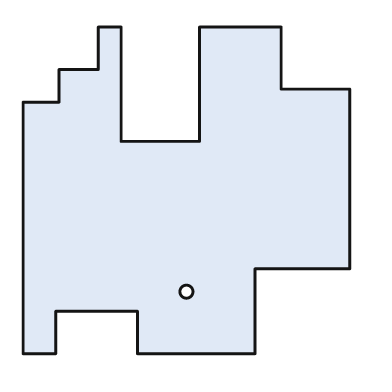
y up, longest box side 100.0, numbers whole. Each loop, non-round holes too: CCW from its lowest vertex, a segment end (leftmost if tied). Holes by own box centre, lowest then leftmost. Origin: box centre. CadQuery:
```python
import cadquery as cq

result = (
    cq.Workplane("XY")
    .moveTo(-50.0, -50.0)
    .lineTo(-40.0, -50.0)
    .lineTo(-40.0, -37.0)
    .lineTo(-15.0, -37.0)
    .lineTo(-15.0, -50.0)
    .lineTo(21.0, -50.0)
    .lineTo(21.0, -24.0)
    .lineTo(50.0, -24.0)
    .lineTo(50.0, 31.0)
    .lineTo(29.0, 31.0)
    .lineTo(29.0, 50.0)
    .lineTo(4.0, 50.0)
    .lineTo(4.0, 15.0)
    .lineTo(-20.0, 15.0)
    .lineTo(-20.0, 50.0)
    .lineTo(-27.0, 50.0)
    .lineTo(-27.0, 37.0)
    .lineTo(-39.0, 37.0)
    .lineTo(-39.0, 27.0)
    .lineTo(-50.0, 27.0)
    .close()
    .moveTo(0.0, -31.0)
    .circle(2.0)
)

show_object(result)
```